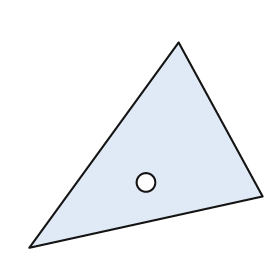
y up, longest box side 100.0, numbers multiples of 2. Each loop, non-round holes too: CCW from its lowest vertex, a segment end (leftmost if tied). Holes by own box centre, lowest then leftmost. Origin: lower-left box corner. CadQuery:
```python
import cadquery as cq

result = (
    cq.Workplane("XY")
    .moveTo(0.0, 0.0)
    .lineTo(100.0, 22.0)
    .lineTo(64.0, 88.0)
    .close()
    .moveTo(50.0, 28.0)
    .circle(4.0)
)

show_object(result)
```